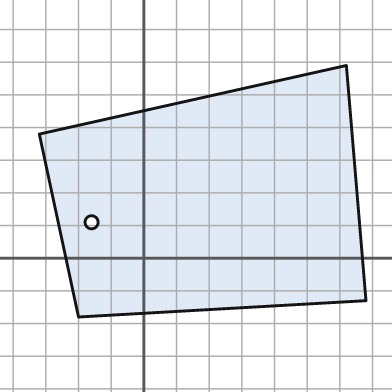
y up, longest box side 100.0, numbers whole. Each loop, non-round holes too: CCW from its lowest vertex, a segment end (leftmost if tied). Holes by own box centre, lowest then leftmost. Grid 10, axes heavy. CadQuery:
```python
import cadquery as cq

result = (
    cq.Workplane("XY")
    .moveTo(-20.0, -18.0)
    .lineTo(68.0, -13.0)
    .lineTo(62.0, 59.0)
    .lineTo(-32.0, 38.0)
    .close()
    .moveTo(-16.0, 11.0)
    .circle(2.0)
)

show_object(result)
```